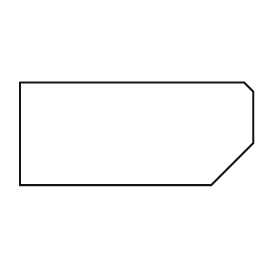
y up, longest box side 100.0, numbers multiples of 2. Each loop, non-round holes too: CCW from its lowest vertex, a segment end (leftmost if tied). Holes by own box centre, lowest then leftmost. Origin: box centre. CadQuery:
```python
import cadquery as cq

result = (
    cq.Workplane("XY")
    .moveTo(-50.0, -22.0)
    .lineTo(32.0, -22.0)
    .lineTo(50.0, -4.0)
    .lineTo(50.0, 18.0)
    .lineTo(46.0, 22.0)
    .lineTo(-50.0, 22.0)
    .close()
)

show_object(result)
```